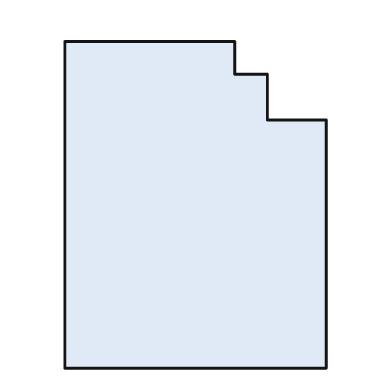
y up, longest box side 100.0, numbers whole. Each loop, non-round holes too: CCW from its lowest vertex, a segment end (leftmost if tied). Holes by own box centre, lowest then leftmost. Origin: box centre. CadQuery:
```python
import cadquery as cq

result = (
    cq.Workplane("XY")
    .moveTo(-40.0, -50.0)
    .lineTo(40.0, -50.0)
    .lineTo(40.0, 26.0)
    .lineTo(22.0, 26.0)
    .lineTo(22.0, 40.0)
    .lineTo(12.0, 40.0)
    .lineTo(12.0, 50.0)
    .lineTo(-40.0, 50.0)
    .close()
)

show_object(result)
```